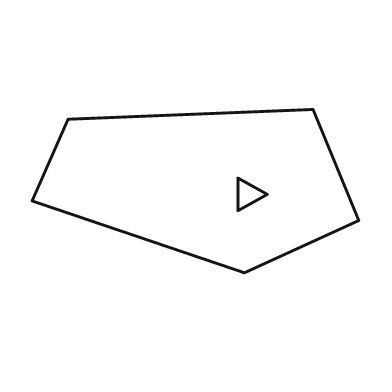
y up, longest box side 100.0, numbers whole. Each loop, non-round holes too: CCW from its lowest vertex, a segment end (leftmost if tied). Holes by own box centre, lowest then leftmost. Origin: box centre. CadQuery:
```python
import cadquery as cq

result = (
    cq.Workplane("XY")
    .moveTo(15.0, -25.0)
    .lineTo(50.0, -9.0)
    .lineTo(36.0, 25.0)
    .lineTo(-39.0, 22.0)
    .lineTo(-50.0, -3.0)
    .close()
    .moveTo(13.0, -6.0)
    .lineTo(22.0, -1.0)
    .lineTo(13.0, 4.0)
    .close()
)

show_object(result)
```